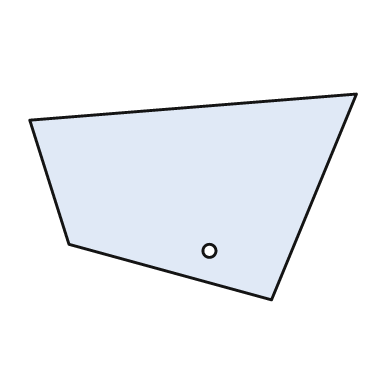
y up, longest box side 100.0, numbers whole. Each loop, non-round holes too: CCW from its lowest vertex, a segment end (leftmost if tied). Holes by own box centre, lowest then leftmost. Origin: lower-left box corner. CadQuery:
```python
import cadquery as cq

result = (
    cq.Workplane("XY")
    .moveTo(74.0, 0.0)
    .lineTo(100.0, 63.0)
    .lineTo(0.0, 55.0)
    .lineTo(12.0, 17.0)
    .close()
    .moveTo(55.0, 15.0)
    .circle(2.0)
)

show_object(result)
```